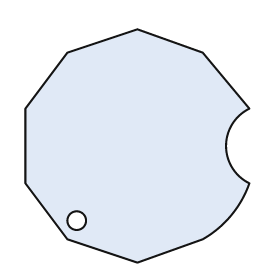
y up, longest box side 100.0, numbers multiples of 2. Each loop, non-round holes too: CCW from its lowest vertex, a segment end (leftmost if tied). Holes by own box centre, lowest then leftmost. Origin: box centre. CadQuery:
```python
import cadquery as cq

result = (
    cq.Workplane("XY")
    .moveTo(0.0, -50.0)
    .lineTo(28.0, -40.0)
    .threePointArc((40.0, -30.0), (48.0, -16.0))
    .threePointArc((38.0, 0.0), (48.0, 16.0))
    .lineTo(28.0, 40.0)
    .lineTo(0.0, 50.0)
    .lineTo(-30.0, 40.0)
    .lineTo(-48.0, 16.0)
    .lineTo(-48.0, -16.0)
    .lineTo(-30.0, -40.0)
    .close()
    .moveTo(-26.0, -32.0)
    .circle(4.0)
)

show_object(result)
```